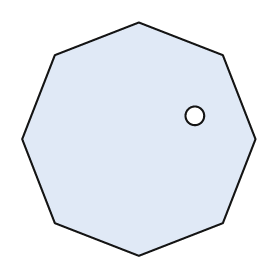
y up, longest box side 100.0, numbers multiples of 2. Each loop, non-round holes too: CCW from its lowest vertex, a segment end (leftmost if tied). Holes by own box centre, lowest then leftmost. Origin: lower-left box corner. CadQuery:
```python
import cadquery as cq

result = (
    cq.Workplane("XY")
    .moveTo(50.0, 0.0)
    .lineTo(86.0, 14.0)
    .lineTo(100.0, 50.0)
    .lineTo(86.0, 86.0)
    .lineTo(50.0, 100.0)
    .lineTo(14.0, 86.0)
    .lineTo(0.0, 50.0)
    .lineTo(14.0, 14.0)
    .close()
    .moveTo(74.0, 60.0)
    .circle(4.0)
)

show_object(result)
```